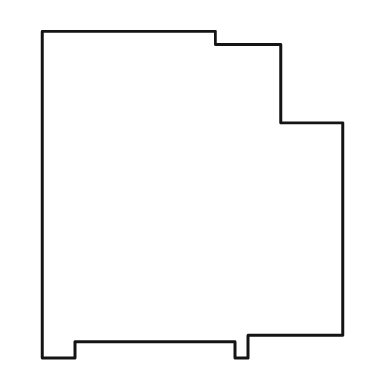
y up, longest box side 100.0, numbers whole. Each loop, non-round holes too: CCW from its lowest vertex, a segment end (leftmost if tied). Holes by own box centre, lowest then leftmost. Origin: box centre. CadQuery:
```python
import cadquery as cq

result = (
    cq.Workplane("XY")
    .moveTo(-46.0, -50.0)
    .lineTo(-36.0, -50.0)
    .lineTo(-36.0, -45.0)
    .lineTo(13.0, -45.0)
    .lineTo(13.0, -50.0)
    .lineTo(17.0, -50.0)
    .lineTo(17.0, -43.0)
    .lineTo(46.0, -43.0)
    .lineTo(46.0, 22.0)
    .lineTo(27.0, 22.0)
    .lineTo(27.0, 46.0)
    .lineTo(7.0, 46.0)
    .lineTo(7.0, 50.0)
    .lineTo(-46.0, 50.0)
    .close()
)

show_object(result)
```